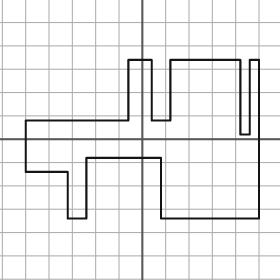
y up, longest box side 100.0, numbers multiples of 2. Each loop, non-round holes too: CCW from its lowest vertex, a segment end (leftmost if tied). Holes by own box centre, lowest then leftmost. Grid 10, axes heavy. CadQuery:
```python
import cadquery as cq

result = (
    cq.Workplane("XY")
    .moveTo(-32.0, -34.0)
    .lineTo(-24.0, -34.0)
    .lineTo(-24.0, -8.0)
    .lineTo(8.0, -8.0)
    .lineTo(8.0, -34.0)
    .lineTo(50.0, -34.0)
    .lineTo(50.0, 34.0)
    .lineTo(46.0, 34.0)
    .lineTo(46.0, 2.0)
    .lineTo(42.0, 2.0)
    .lineTo(42.0, 34.0)
    .lineTo(12.0, 34.0)
    .lineTo(12.0, 8.0)
    .lineTo(4.0, 8.0)
    .lineTo(4.0, 34.0)
    .lineTo(-6.0, 34.0)
    .lineTo(-6.0, 8.0)
    .lineTo(-50.0, 8.0)
    .lineTo(-50.0, -14.0)
    .lineTo(-32.0, -14.0)
    .close()
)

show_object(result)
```